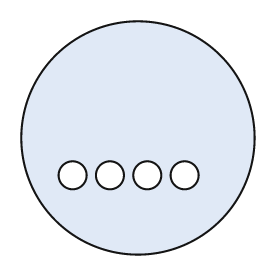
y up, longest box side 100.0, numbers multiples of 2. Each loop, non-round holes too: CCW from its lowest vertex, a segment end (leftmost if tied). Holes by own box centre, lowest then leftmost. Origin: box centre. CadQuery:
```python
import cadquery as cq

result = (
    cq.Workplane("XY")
    .moveTo(0.0, 0.0)
    .circle(50.0)
    .moveTo(-28.0, -16.0)
    .circle(6.0)
    .moveTo(-12.0, -16.0)
    .circle(6.0)
    .moveTo(4.0, -16.0)
    .circle(6.0)
    .moveTo(20.0, -16.0)
    .circle(6.0)
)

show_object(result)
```